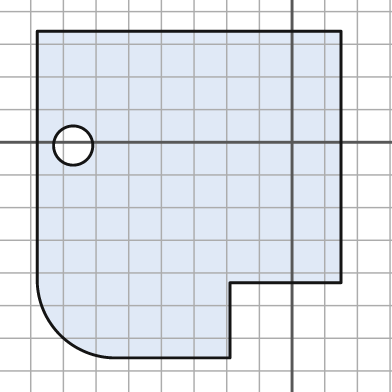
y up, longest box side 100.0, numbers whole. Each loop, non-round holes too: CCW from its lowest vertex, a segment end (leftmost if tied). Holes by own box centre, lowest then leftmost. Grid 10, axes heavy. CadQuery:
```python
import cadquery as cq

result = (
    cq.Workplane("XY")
    .moveTo(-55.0, -66.0)
    .lineTo(-19.0, -66.0)
    .lineTo(-19.0, -43.0)
    .lineTo(15.0, -43.0)
    .lineTo(15.0, 34.0)
    .lineTo(-78.0, 34.0)
    .lineTo(-78.0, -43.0)
    .threePointArc((-71.0, -59.0), (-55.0, -66.0))
    .close()
    .moveTo(-67.0, -1.0)
    .circle(6.0)
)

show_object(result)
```